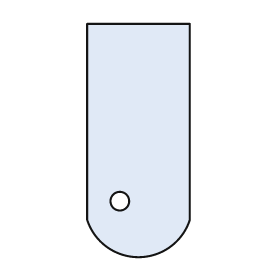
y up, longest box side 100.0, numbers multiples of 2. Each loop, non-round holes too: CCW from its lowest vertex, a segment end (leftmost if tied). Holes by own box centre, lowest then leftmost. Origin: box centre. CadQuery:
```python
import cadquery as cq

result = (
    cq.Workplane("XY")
    .moveTo(-22.0, -34.0)
    .threePointArc((0.0, -50.0), (22.0, -34.0))
    .lineTo(22.0, 50.0)
    .lineTo(-22.0, 50.0)
    .close()
    .moveTo(-8.0, -26.0)
    .circle(4.0)
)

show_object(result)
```